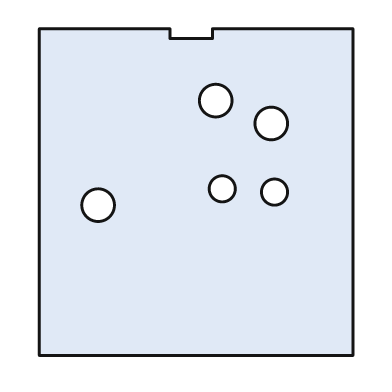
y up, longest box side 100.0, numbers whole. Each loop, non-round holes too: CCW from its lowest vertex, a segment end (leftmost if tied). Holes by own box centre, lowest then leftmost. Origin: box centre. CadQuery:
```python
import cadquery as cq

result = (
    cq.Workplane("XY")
    .moveTo(-48.0, -50.0)
    .lineTo(48.0, -50.0)
    .lineTo(48.0, 50.0)
    .lineTo(5.0, 50.0)
    .lineTo(5.0, 47.0)
    .lineTo(-8.0, 47.0)
    .lineTo(-8.0, 50.0)
    .lineTo(-48.0, 50.0)
    .close()
    .moveTo(-30.0, -4.0)
    .circle(5.0)
    .moveTo(24.0, 0.0)
    .circle(4.0)
    .moveTo(8.0, 1.0)
    .circle(4.0)
    .moveTo(23.0, 21.0)
    .circle(5.0)
    .moveTo(6.0, 28.0)
    .circle(5.0)
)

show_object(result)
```